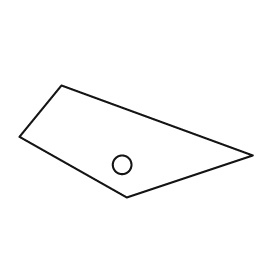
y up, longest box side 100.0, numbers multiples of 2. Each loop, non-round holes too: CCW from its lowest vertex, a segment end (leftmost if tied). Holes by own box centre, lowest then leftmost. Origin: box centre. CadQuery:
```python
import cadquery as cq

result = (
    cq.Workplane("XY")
    .moveTo(-4.0, -24.0)
    .lineTo(50.0, -6.0)
    .lineTo(-32.0, 24.0)
    .lineTo(-50.0, 2.0)
    .close()
    .moveTo(-6.0, -10.0)
    .circle(4.0)
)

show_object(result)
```